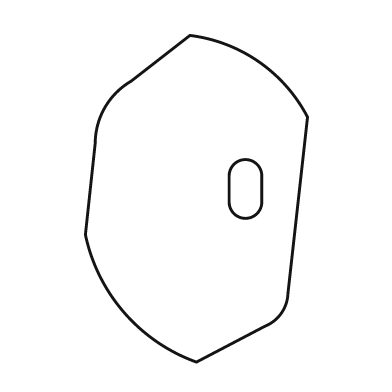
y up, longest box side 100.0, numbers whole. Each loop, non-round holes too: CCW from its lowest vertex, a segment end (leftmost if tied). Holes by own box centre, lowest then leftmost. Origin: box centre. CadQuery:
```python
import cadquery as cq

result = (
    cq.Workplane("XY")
    .moveTo(0.0, -50.0)
    .lineTo(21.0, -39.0)
    .threePointArc((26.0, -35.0), (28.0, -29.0))
    .lineTo(34.0, 25.0)
    .threePointArc((19.0, 42.0), (-2.0, 50.0))
    .lineTo(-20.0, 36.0)
    .threePointArc((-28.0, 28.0), (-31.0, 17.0))
    .lineTo(-34.0, -11.0)
    .threePointArc((-22.0, -35.0), (0.0, -50.0))
    .close()
    .moveTo(10.0, -1.0)
    .threePointArc((15.0, -6.0), (20.0, -1.0))
    .lineTo(20.0, 7.0)
    .threePointArc((15.0, 12.0), (10.0, 7.0))
    .close()
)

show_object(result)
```